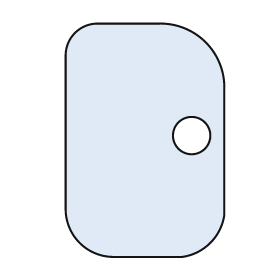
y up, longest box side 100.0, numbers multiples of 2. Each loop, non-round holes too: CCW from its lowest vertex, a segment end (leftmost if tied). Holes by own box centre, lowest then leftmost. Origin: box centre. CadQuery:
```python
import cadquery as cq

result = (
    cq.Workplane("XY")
    .moveTo(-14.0, -50.0)
    .lineTo(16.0, -50.0)
    .threePointArc((28.0, -44.0), (34.0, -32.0))
    .lineTo(34.0, 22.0)
    .threePointArc((26.0, 42.0), (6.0, 50.0))
    .lineTo(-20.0, 50.0)
    .threePointArc((-30.0, 46.0), (-34.0, 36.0))
    .lineTo(-34.0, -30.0)
    .threePointArc((-28.0, -44.0), (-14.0, -50.0))
    .close()
    .moveTo(20.0, 2.0)
    .circle(8.0)
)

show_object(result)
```